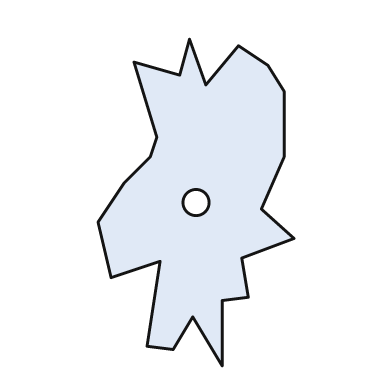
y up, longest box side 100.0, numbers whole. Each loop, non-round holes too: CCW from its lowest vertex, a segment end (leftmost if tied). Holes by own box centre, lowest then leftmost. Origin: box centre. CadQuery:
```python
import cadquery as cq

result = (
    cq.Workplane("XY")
    .moveTo(8.0, -50.0)
    .lineTo(8.0, -30.0)
    .lineTo(16.0, -29.0)
    .lineTo(14.0, -17.0)
    .lineTo(30.0, -11.0)
    .lineTo(20.0, -2.0)
    .lineTo(27.0, 14.0)
    .lineTo(27.0, 34.0)
    .lineTo(22.0, 42.0)
    .lineTo(13.0, 48.0)
    .lineTo(3.0, 36.0)
    .lineTo(-2.0, 50.0)
    .lineTo(-5.0, 39.0)
    .lineTo(-19.0, 43.0)
    .lineTo(-12.0, 20.0)
    .lineTo(-14.0, 14.0)
    .lineTo(-22.0, 6.0)
    .lineTo(-30.0, -6.0)
    .lineTo(-26.0, -23.0)
    .lineTo(-11.0, -18.0)
    .lineTo(-15.0, -44.0)
    .lineTo(-7.0, -45.0)
    .lineTo(-1.0, -35.0)
    .close()
    .moveTo(0.0, 0.0)
    .circle(4.0)
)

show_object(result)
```